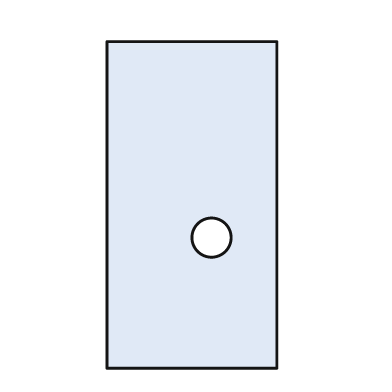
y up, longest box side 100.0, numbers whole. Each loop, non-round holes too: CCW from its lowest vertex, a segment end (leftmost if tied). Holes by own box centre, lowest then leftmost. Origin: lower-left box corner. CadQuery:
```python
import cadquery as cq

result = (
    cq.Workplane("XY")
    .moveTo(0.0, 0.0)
    .lineTo(52.0, 0.0)
    .lineTo(52.0, 100.0)
    .lineTo(0.0, 100.0)
    .close()
    .moveTo(32.0, 40.0)
    .circle(6.0)
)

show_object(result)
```